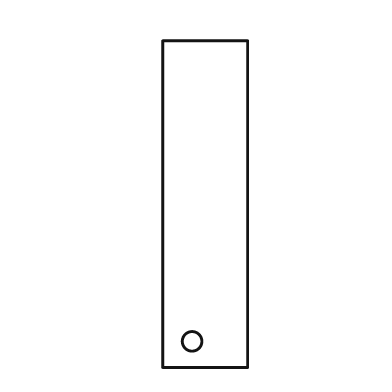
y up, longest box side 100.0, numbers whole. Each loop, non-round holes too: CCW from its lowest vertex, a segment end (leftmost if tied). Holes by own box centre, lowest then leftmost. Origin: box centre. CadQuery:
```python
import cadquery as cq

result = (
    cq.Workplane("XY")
    .moveTo(-13.0, -50.0)
    .lineTo(13.0, -50.0)
    .lineTo(13.0, 50.0)
    .lineTo(-13.0, 50.0)
    .close()
    .moveTo(-4.0, -42.0)
    .circle(3.0)
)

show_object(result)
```